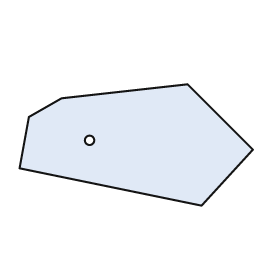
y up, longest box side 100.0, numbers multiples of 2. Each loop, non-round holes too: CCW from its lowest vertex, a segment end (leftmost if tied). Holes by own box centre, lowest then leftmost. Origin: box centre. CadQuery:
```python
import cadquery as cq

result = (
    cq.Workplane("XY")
    .moveTo(28.0, -26.0)
    .lineTo(50.0, -2.0)
    .lineTo(22.0, 26.0)
    .lineTo(-32.0, 20.0)
    .lineTo(-46.0, 12.0)
    .lineTo(-50.0, -10.0)
    .close()
    .moveTo(-20.0, 2.0)
    .circle(2.0)
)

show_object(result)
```